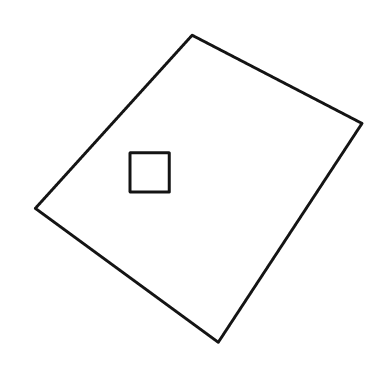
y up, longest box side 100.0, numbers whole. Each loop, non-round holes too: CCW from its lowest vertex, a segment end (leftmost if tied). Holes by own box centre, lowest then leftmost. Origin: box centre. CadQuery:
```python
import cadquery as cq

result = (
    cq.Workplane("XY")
    .moveTo(6.0, -47.0)
    .lineTo(50.0, 20.0)
    .lineTo(-2.0, 47.0)
    .lineTo(-50.0, -6.0)
    .close()
    .moveTo(-21.0, -1.0)
    .lineTo(-9.0, -1.0)
    .lineTo(-9.0, 11.0)
    .lineTo(-21.0, 11.0)
    .close()
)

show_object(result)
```